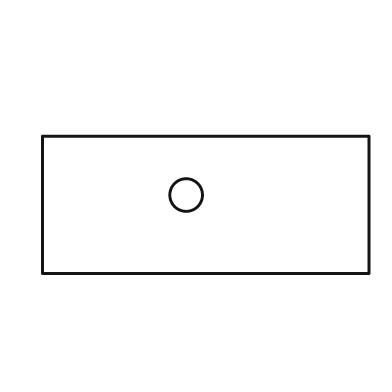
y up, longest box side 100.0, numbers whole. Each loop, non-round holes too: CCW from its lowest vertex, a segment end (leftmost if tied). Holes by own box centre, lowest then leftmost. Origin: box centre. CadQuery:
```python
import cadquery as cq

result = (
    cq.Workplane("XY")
    .moveTo(-50.0, -21.0)
    .lineTo(50.0, -21.0)
    .lineTo(50.0, 21.0)
    .lineTo(-50.0, 21.0)
    .close()
    .moveTo(-6.0, 3.0)
    .circle(5.0)
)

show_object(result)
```